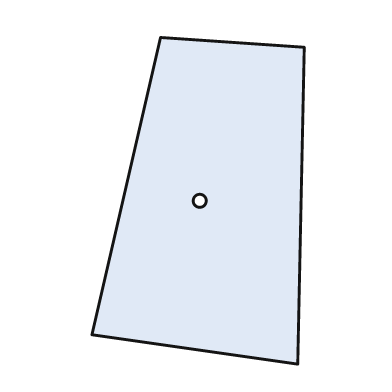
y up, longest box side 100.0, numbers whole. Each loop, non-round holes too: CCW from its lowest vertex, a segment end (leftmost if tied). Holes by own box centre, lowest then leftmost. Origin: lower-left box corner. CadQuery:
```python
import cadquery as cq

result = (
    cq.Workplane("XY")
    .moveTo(63.0, 0.0)
    .lineTo(65.0, 97.0)
    .lineTo(21.0, 100.0)
    .lineTo(0.0, 9.0)
    .close()
    .moveTo(33.0, 50.0)
    .circle(2.0)
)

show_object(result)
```